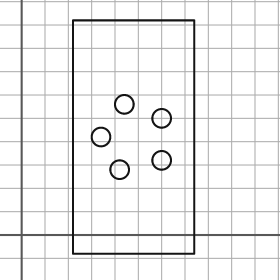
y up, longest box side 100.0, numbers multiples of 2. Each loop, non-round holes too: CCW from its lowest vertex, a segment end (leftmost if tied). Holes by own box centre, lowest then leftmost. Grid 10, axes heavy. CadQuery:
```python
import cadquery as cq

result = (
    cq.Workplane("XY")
    .moveTo(22.0, -8.0)
    .lineTo(74.0, -8.0)
    .lineTo(74.0, 92.0)
    .lineTo(22.0, 92.0)
    .close()
    .moveTo(42.0, 28.0)
    .circle(4.0)
    .moveTo(60.0, 32.0)
    .circle(4.0)
    .moveTo(34.0, 42.0)
    .circle(4.0)
    .moveTo(60.0, 50.0)
    .circle(4.0)
    .moveTo(44.0, 56.0)
    .circle(4.0)
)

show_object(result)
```